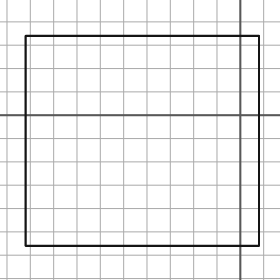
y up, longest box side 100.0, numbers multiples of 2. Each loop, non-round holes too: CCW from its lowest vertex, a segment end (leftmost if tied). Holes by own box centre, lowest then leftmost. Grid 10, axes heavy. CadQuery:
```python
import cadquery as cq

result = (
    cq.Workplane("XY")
    .moveTo(-92.0, -56.0)
    .lineTo(8.0, -56.0)
    .lineTo(8.0, 34.0)
    .lineTo(-92.0, 34.0)
    .close()
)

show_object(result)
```